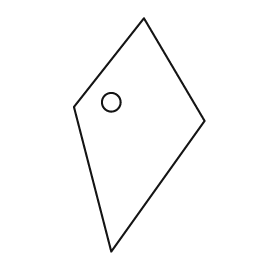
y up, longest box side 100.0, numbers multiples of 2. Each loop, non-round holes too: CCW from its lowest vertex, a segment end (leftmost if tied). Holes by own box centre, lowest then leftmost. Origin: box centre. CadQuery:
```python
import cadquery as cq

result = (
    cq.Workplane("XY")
    .moveTo(-12.0, -50.0)
    .lineTo(28.0, 6.0)
    .lineTo(2.0, 50.0)
    .lineTo(-28.0, 12.0)
    .close()
    .moveTo(-12.0, 14.0)
    .circle(4.0)
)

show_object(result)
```